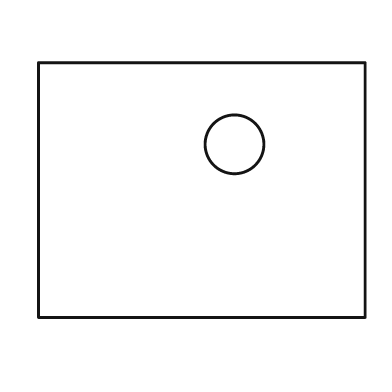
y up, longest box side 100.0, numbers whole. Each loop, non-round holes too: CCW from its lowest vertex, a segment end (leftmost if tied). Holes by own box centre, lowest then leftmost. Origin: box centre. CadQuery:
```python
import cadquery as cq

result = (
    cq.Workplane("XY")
    .moveTo(-50.0, -39.0)
    .lineTo(50.0, -39.0)
    .lineTo(50.0, 39.0)
    .lineTo(-50.0, 39.0)
    .close()
    .moveTo(10.0, 14.0)
    .circle(9.0)
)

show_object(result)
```